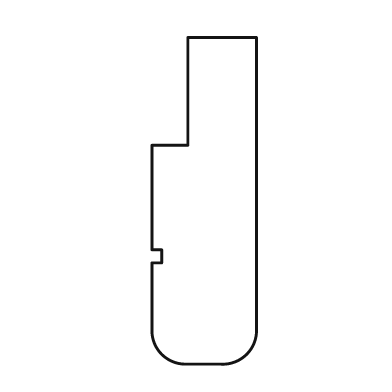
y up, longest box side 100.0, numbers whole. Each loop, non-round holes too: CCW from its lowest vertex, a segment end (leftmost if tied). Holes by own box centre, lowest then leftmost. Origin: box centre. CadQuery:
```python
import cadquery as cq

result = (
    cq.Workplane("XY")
    .moveTo(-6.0, -50.0)
    .lineTo(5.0, -50.0)
    .threePointArc((13.0, -47.0), (16.0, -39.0))
    .lineTo(16.0, 50.0)
    .lineTo(-5.0, 50.0)
    .lineTo(-5.0, 17.0)
    .lineTo(-16.0, 17.0)
    .lineTo(-16.0, -15.0)
    .lineTo(-13.0, -15.0)
    .lineTo(-13.0, -19.0)
    .lineTo(-16.0, -19.0)
    .lineTo(-16.0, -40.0)
    .threePointArc((-13.0, -47.0), (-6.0, -50.0))
    .close()
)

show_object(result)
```